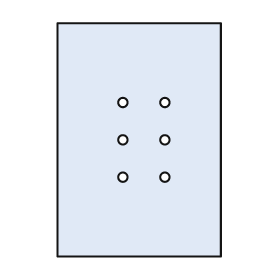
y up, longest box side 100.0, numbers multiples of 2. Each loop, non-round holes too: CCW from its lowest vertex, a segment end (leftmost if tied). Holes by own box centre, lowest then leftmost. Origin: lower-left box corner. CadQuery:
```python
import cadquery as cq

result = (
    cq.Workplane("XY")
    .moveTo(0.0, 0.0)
    .lineTo(70.0, 0.0)
    .lineTo(70.0, 100.0)
    .lineTo(0.0, 100.0)
    .close()
    .moveTo(28.0, 34.0)
    .circle(2.0)
    .moveTo(46.0, 34.0)
    .circle(2.0)
    .moveTo(28.0, 50.0)
    .circle(2.0)
    .moveTo(46.0, 50.0)
    .circle(2.0)
    .moveTo(28.0, 66.0)
    .circle(2.0)
    .moveTo(46.0, 66.0)
    .circle(2.0)
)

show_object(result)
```